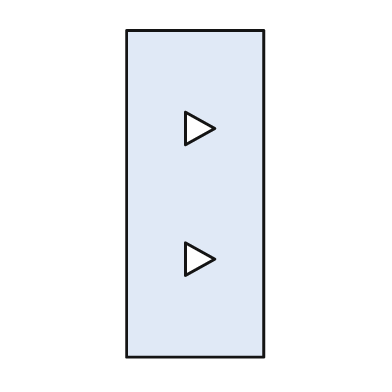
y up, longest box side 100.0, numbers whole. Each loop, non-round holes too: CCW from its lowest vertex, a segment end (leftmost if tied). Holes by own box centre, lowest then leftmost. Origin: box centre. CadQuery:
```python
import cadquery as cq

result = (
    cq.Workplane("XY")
    .moveTo(-21.0, -50.0)
    .lineTo(21.0, -50.0)
    .lineTo(21.0, 50.0)
    .lineTo(-21.0, 50.0)
    .close()
    .moveTo(-3.0, -25.0)
    .lineTo(6.0, -20.0)
    .lineTo(-3.0, -15.0)
    .close()
    .moveTo(-3.0, 15.0)
    .lineTo(6.0, 20.0)
    .lineTo(-3.0, 25.0)
    .close()
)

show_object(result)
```